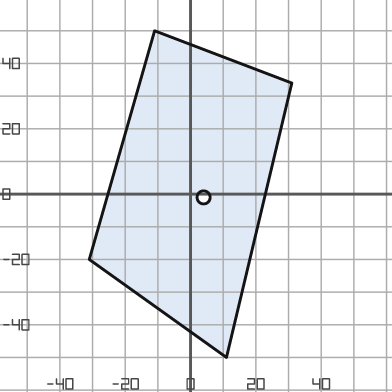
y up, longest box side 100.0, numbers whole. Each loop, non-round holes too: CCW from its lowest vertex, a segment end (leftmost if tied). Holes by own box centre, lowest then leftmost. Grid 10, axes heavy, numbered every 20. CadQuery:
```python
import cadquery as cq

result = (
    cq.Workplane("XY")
    .moveTo(11.0, -50.0)
    .lineTo(31.0, 34.0)
    .lineTo(-11.0, 50.0)
    .lineTo(-31.0, -20.0)
    .close()
    .moveTo(4.0, -1.0)
    .circle(2.0)
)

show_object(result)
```